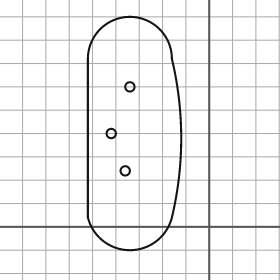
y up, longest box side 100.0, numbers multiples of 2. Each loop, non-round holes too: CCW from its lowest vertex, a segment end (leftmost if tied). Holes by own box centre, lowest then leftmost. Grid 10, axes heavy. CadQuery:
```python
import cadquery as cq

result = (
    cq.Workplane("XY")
    .moveTo(-52.0, 4.0)
    .threePointArc((-34.0, -10.0), (-16.0, 4.0))
    .threePointArc((-12.0, 38.0), (-16.0, 72.0))
    .threePointArc((-34.0, 90.0), (-52.0, 72.0))
    .close()
    .moveTo(-36.0, 24.0)
    .circle(2.0)
    .moveTo(-42.0, 40.0)
    .circle(2.0)
    .moveTo(-34.0, 60.0)
    .circle(2.0)
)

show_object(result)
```